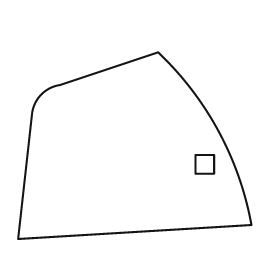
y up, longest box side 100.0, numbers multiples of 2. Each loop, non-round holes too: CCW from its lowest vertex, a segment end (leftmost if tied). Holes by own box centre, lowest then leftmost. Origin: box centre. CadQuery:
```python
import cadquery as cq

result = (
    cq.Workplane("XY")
    .moveTo(-50.0, -40.0)
    .lineTo(50.0, -34.0)
    .threePointArc((36.0, 6.0), (10.0, 40.0))
    .lineTo(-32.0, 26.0)
    .threePointArc((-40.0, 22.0), (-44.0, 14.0))
    .close()
    .moveTo(26.0, -12.0)
    .lineTo(34.0, -12.0)
    .lineTo(34.0, -4.0)
    .lineTo(26.0, -4.0)
    .close()
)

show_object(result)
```